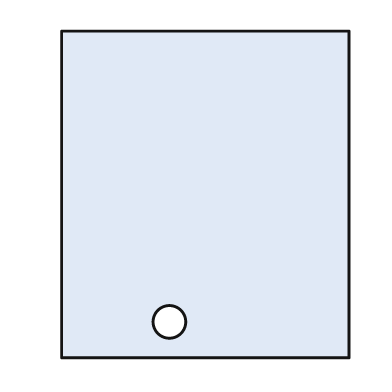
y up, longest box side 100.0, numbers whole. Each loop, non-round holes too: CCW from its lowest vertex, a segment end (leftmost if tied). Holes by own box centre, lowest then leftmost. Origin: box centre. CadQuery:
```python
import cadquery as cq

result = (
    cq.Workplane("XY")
    .moveTo(-44.0, -50.0)
    .lineTo(44.0, -50.0)
    .lineTo(44.0, 50.0)
    .lineTo(-44.0, 50.0)
    .close()
    .moveTo(-11.0, -39.0)
    .circle(5.0)
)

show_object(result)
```